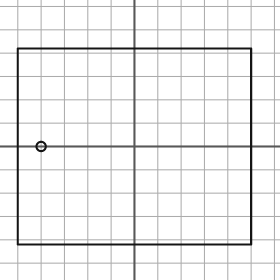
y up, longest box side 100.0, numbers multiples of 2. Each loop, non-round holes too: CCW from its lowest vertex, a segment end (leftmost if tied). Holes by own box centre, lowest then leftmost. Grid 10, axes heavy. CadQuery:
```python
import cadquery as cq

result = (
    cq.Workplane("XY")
    .moveTo(-50.0, -42.0)
    .lineTo(50.0, -42.0)
    .lineTo(50.0, 42.0)
    .lineTo(-50.0, 42.0)
    .close()
    .moveTo(-40.0, 0.0)
    .circle(2.0)
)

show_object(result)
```